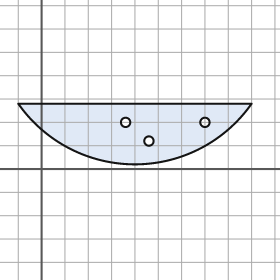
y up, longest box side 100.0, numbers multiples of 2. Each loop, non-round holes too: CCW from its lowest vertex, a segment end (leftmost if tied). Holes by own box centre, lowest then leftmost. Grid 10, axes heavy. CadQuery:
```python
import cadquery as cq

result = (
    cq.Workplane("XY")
    .moveTo(-10.0, 28.0)
    .threePointArc((40.0, 2.0), (90.0, 28.0))
    .close()
    .moveTo(46.0, 12.0)
    .circle(2.0)
    .moveTo(36.0, 20.0)
    .circle(2.0)
    .moveTo(70.0, 20.0)
    .circle(2.0)
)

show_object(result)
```